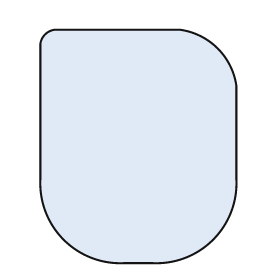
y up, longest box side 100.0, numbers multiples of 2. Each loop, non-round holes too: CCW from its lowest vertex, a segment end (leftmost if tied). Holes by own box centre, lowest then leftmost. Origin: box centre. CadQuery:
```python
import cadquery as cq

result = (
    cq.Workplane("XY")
    .moveTo(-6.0, -50.0)
    .lineTo(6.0, -50.0)
    .threePointArc((32.0, -40.0), (42.0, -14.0))
    .lineTo(42.0, 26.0)
    .threePointArc((34.0, 42.0), (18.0, 50.0))
    .lineTo(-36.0, 50.0)
    .threePointArc((-40.0, 48.0), (-42.0, 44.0))
    .lineTo(-42.0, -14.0)
    .threePointArc((-32.0, -40.0), (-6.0, -50.0))
    .close()
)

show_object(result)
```